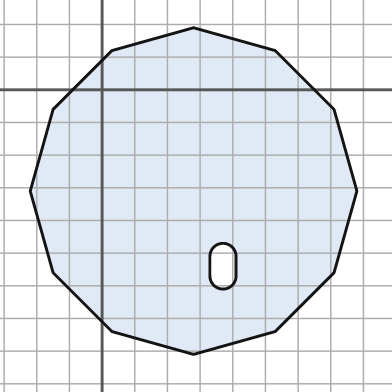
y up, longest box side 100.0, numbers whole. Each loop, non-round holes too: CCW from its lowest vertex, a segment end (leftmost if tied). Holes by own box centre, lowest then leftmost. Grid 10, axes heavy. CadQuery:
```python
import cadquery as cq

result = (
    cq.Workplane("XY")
    .moveTo(28.0, -81.0)
    .lineTo(53.0, -74.0)
    .lineTo(71.0, -56.0)
    .lineTo(78.0, -31.0)
    .lineTo(71.0, -6.0)
    .lineTo(53.0, 12.0)
    .lineTo(28.0, 19.0)
    .lineTo(3.0, 12.0)
    .lineTo(-15.0, -6.0)
    .lineTo(-22.0, -31.0)
    .lineTo(-15.0, -56.0)
    .lineTo(3.0, -74.0)
    .close()
    .moveTo(33.0, -57.0)
    .threePointArc((37.0, -61.0), (41.0, -57.0))
    .lineTo(41.0, -51.0)
    .threePointArc((37.0, -47.0), (33.0, -51.0))
    .close()
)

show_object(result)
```